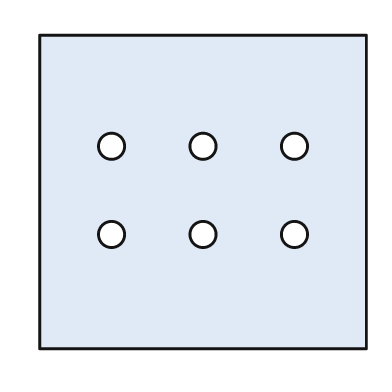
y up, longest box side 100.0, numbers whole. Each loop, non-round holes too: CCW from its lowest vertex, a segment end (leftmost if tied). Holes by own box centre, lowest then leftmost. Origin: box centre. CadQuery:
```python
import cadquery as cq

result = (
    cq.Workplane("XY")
    .moveTo(-50.0, -48.0)
    .lineTo(50.0, -48.0)
    .lineTo(50.0, 48.0)
    .lineTo(-50.0, 48.0)
    .close()
    .moveTo(-28.0, -13.0)
    .circle(4.0)
    .moveTo(0.0, -13.0)
    .circle(4.0)
    .moveTo(28.0, -13.0)
    .circle(4.0)
    .moveTo(-28.0, 14.0)
    .circle(4.0)
    .moveTo(0.0, 14.0)
    .circle(4.0)
    .moveTo(28.0, 14.0)
    .circle(4.0)
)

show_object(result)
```